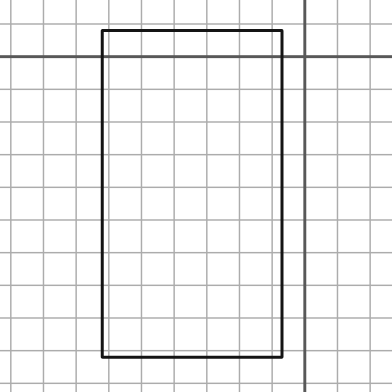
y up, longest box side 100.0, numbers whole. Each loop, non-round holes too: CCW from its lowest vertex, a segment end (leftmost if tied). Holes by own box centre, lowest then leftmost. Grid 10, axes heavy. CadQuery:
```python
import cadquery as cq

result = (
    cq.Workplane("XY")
    .moveTo(-62.0, -92.0)
    .lineTo(-7.0, -92.0)
    .lineTo(-7.0, 8.0)
    .lineTo(-62.0, 8.0)
    .close()
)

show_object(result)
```